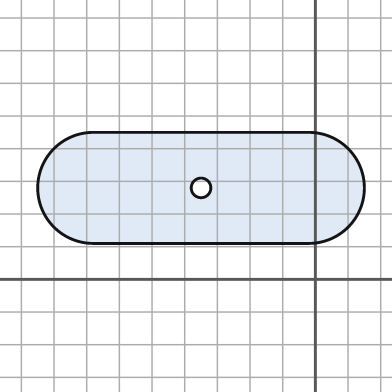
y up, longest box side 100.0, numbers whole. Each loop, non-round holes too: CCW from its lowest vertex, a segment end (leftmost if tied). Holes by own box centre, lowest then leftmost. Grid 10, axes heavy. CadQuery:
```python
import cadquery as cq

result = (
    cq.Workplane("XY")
    .moveTo(-68.0, 11.0)
    .lineTo(-2.0, 11.0)
    .threePointArc((15.0, 28.0), (-2.0, 45.0))
    .lineTo(-68.0, 45.0)
    .threePointArc((-85.0, 28.0), (-68.0, 11.0))
    .close()
    .moveTo(-35.0, 28.0)
    .circle(3.0)
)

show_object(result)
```